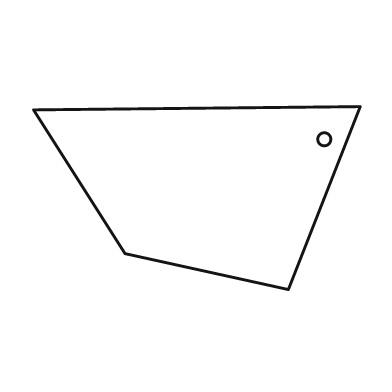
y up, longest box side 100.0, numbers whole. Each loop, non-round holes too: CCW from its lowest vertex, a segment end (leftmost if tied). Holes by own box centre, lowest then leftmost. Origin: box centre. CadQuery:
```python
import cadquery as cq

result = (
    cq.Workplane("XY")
    .moveTo(28.0, -28.0)
    .lineTo(50.0, 28.0)
    .lineTo(-50.0, 27.0)
    .lineTo(-22.0, -17.0)
    .close()
    .moveTo(39.0, 18.0)
    .circle(2.0)
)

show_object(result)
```